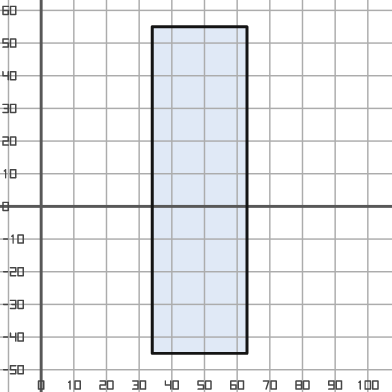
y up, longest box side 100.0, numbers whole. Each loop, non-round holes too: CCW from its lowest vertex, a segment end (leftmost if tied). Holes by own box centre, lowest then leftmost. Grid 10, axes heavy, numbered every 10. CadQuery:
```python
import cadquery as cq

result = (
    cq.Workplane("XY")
    .moveTo(34.0, -45.0)
    .lineTo(63.0, -45.0)
    .lineTo(63.0, 55.0)
    .lineTo(34.0, 55.0)
    .close()
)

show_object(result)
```